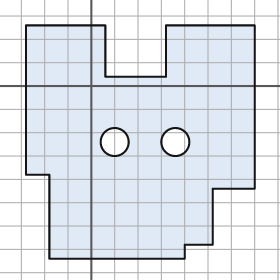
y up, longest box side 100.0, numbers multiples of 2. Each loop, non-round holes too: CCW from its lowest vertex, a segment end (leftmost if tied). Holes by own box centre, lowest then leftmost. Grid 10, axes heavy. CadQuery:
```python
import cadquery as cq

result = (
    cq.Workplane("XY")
    .moveTo(-18.0, -74.0)
    .lineTo(40.0, -74.0)
    .lineTo(40.0, -68.0)
    .lineTo(52.0, -68.0)
    .lineTo(52.0, -44.0)
    .lineTo(70.0, -44.0)
    .lineTo(70.0, 26.0)
    .lineTo(32.0, 26.0)
    .lineTo(32.0, 4.0)
    .lineTo(6.0, 4.0)
    .lineTo(6.0, 26.0)
    .lineTo(-28.0, 26.0)
    .lineTo(-28.0, -38.0)
    .lineTo(-18.0, -38.0)
    .close()
    .moveTo(10.0, -24.0)
    .circle(6.0)
    .moveTo(36.0, -24.0)
    .circle(6.0)
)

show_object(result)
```